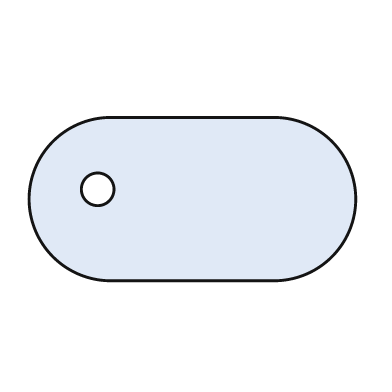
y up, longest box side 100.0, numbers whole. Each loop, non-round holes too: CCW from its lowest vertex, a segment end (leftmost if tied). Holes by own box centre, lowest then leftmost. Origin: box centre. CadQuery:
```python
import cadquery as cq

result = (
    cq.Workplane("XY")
    .moveTo(-25.0, -25.0)
    .lineTo(25.0, -25.0)
    .threePointArc((50.0, 0.0), (25.0, 25.0))
    .lineTo(-25.0, 25.0)
    .threePointArc((-50.0, 0.0), (-25.0, -25.0))
    .close()
    .moveTo(-29.0, 3.0)
    .circle(5.0)
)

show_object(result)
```